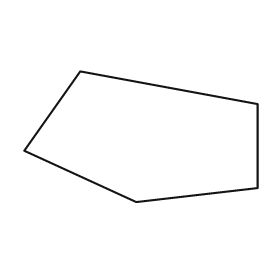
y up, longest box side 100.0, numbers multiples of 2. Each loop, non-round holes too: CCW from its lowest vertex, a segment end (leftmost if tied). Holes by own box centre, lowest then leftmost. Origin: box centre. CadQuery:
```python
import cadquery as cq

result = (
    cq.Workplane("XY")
    .moveTo(-2.0, -28.0)
    .lineTo(50.0, -22.0)
    .lineTo(50.0, 14.0)
    .lineTo(-26.0, 28.0)
    .lineTo(-50.0, -6.0)
    .close()
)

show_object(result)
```